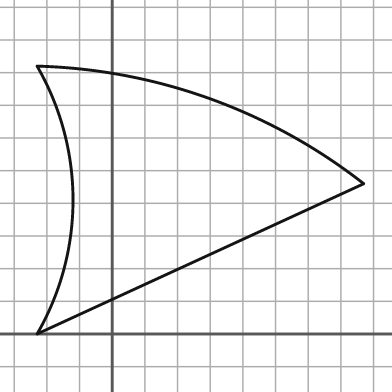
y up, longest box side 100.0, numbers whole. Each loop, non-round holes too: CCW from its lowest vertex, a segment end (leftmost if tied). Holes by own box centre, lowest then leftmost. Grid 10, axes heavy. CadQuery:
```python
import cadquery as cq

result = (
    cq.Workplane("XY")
    .moveTo(-23.0, 0.0)
    .lineTo(77.0, 46.0)
    .threePointArc((30.0, 72.0), (-23.0, 82.0))
    .threePointArc((-12.0, 41.0), (-23.0, 0.0))
    .close()
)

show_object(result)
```